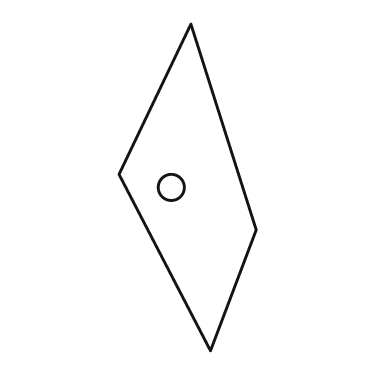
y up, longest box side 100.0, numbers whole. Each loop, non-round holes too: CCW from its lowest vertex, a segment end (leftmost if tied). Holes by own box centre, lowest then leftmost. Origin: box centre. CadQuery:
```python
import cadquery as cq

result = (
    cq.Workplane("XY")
    .moveTo(7.0, -50.0)
    .lineTo(21.0, -13.0)
    .lineTo(1.0, 50.0)
    .lineTo(-21.0, 4.0)
    .close()
    .moveTo(-5.0, 0.0)
    .circle(4.0)
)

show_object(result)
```